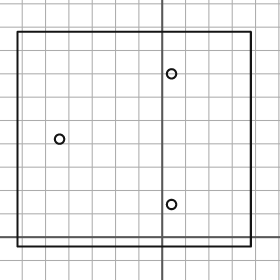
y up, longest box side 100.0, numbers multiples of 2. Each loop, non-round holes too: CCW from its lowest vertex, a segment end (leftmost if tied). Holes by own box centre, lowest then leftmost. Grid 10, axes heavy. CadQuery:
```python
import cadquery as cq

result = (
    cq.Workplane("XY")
    .moveTo(-62.0, -4.0)
    .lineTo(38.0, -4.0)
    .lineTo(38.0, 88.0)
    .lineTo(-62.0, 88.0)
    .close()
    .moveTo(4.0, 14.0)
    .circle(2.0)
    .moveTo(-44.0, 42.0)
    .circle(2.0)
    .moveTo(4.0, 70.0)
    .circle(2.0)
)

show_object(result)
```